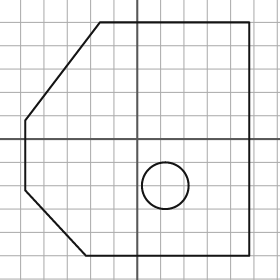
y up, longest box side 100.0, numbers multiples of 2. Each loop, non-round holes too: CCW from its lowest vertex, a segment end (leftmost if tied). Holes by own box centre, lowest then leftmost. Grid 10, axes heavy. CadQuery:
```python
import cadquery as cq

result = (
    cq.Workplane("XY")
    .moveTo(-22.0, -50.0)
    .lineTo(48.0, -50.0)
    .lineTo(48.0, 50.0)
    .lineTo(-16.0, 50.0)
    .lineTo(-48.0, 8.0)
    .lineTo(-48.0, -22.0)
    .close()
    .moveTo(12.0, -20.0)
    .circle(10.0)
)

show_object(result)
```